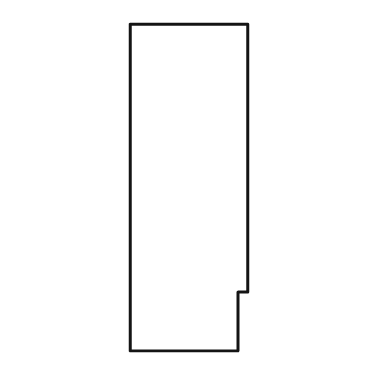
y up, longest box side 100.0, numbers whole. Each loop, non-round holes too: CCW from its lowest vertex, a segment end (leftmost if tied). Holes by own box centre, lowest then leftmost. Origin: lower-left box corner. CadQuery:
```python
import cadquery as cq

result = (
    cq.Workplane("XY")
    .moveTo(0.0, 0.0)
    .lineTo(33.0, 0.0)
    .lineTo(33.0, 18.0)
    .lineTo(36.0, 18.0)
    .lineTo(36.0, 100.0)
    .lineTo(0.0, 100.0)
    .close()
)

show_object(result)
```